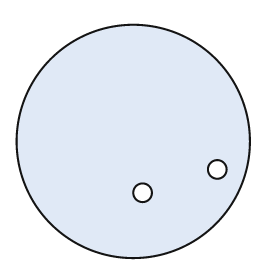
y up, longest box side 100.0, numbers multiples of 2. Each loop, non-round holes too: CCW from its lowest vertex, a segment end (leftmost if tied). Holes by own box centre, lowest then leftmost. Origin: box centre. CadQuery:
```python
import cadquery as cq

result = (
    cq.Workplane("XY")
    .moveTo(0.0, 0.0)
    .circle(50.0)
    .moveTo(4.0, -22.0)
    .circle(4.0)
    .moveTo(36.0, -12.0)
    .circle(4.0)
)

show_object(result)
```